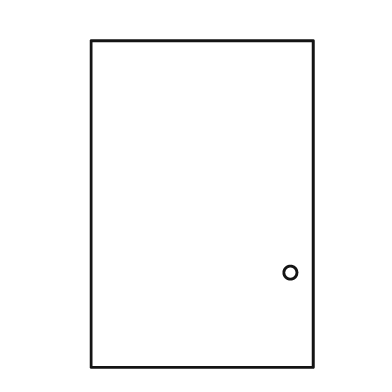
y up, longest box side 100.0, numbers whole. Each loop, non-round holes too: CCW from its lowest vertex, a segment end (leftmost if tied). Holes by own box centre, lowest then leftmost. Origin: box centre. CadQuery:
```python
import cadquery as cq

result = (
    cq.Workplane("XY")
    .moveTo(-34.0, -50.0)
    .lineTo(34.0, -50.0)
    .lineTo(34.0, 50.0)
    .lineTo(-34.0, 50.0)
    .close()
    .moveTo(27.0, -21.0)
    .circle(2.0)
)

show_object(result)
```